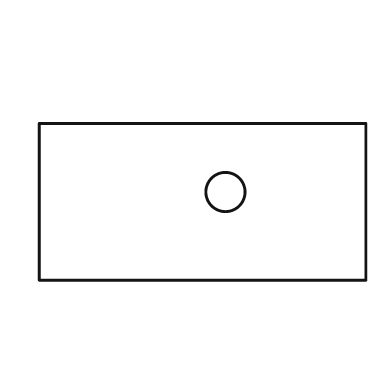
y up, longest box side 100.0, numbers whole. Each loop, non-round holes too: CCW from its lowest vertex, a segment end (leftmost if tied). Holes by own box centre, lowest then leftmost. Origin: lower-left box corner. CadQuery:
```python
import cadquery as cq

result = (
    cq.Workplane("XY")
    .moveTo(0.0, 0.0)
    .lineTo(100.0, 0.0)
    .lineTo(100.0, 48.0)
    .lineTo(0.0, 48.0)
    .close()
    .moveTo(57.0, 27.0)
    .circle(6.0)
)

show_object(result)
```